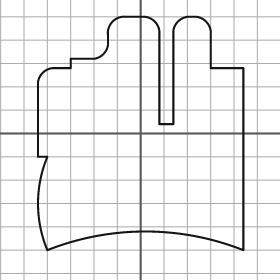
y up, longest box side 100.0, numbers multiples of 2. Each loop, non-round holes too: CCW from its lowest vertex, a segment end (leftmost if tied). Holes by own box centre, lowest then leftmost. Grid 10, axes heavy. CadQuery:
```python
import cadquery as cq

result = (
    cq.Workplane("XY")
    .moveTo(-40.0, -50.0)
    .threePointArc((2.0, -42.0), (44.0, -50.0))
    .lineTo(44.0, 28.0)
    .lineTo(30.0, 28.0)
    .lineTo(30.0, 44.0)
    .threePointArc((28.0, 48.0), (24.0, 50.0))
    .lineTo(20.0, 50.0)
    .threePointArc((16.0, 48.0), (14.0, 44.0))
    .lineTo(14.0, 4.0)
    .lineTo(8.0, 4.0)
    .lineTo(8.0, 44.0)
    .threePointArc((6.0, 48.0), (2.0, 50.0))
    .lineTo(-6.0, 50.0)
    .threePointArc((-12.0, 48.0), (-14.0, 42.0))
    .lineTo(-14.0, 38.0)
    .threePointArc((-16.0, 34.0), (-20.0, 32.0))
    .lineTo(-30.0, 32.0)
    .lineTo(-30.0, 28.0)
    .lineTo(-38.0, 28.0)
    .threePointArc((-42.0, 26.0), (-44.0, 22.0))
    .lineTo(-44.0, -10.0)
    .lineTo(-40.0, -10.0)
    .threePointArc((-44.0, -30.0), (-40.0, -50.0))
    .close()
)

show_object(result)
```